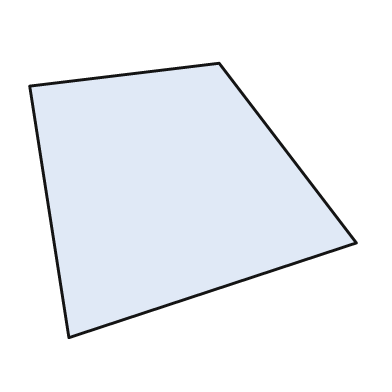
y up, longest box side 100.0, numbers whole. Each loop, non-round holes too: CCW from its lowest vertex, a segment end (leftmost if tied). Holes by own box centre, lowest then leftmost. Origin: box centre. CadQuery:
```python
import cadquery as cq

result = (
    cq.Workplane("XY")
    .moveTo(-38.0, -42.0)
    .lineTo(50.0, -13.0)
    .lineTo(8.0, 42.0)
    .lineTo(-50.0, 35.0)
    .close()
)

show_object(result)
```